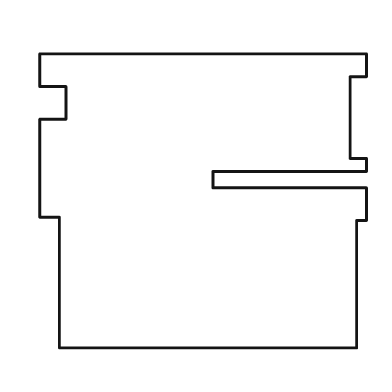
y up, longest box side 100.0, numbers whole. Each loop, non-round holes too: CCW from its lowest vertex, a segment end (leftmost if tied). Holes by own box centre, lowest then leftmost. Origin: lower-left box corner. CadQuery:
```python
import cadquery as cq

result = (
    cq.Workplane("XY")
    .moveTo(6.0, 0.0)
    .lineTo(97.0, 0.0)
    .lineTo(97.0, 39.0)
    .lineTo(100.0, 39.0)
    .lineTo(100.0, 49.0)
    .lineTo(53.0, 49.0)
    .lineTo(53.0, 54.0)
    .lineTo(100.0, 54.0)
    .lineTo(100.0, 58.0)
    .lineTo(95.0, 58.0)
    .lineTo(95.0, 83.0)
    .lineTo(100.0, 83.0)
    .lineTo(100.0, 90.0)
    .lineTo(0.0, 90.0)
    .lineTo(0.0, 80.0)
    .lineTo(8.0, 80.0)
    .lineTo(8.0, 70.0)
    .lineTo(0.0, 70.0)
    .lineTo(0.0, 40.0)
    .lineTo(6.0, 40.0)
    .close()
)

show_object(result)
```